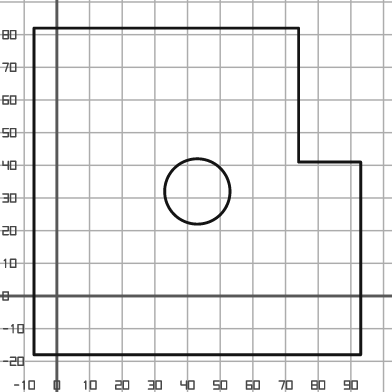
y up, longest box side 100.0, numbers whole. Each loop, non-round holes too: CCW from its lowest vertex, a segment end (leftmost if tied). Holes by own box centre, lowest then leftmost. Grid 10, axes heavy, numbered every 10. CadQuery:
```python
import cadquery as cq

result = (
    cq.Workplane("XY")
    .moveTo(-7.0, -18.0)
    .lineTo(93.0, -18.0)
    .lineTo(93.0, 41.0)
    .lineTo(74.0, 41.0)
    .lineTo(74.0, 82.0)
    .lineTo(-7.0, 82.0)
    .close()
    .moveTo(43.0, 32.0)
    .circle(10.0)
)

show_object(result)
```